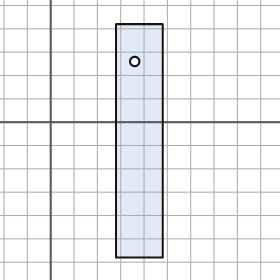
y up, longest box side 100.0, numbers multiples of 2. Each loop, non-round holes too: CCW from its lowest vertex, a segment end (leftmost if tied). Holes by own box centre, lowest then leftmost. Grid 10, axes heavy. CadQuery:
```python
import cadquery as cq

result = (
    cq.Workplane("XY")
    .moveTo(28.0, -58.0)
    .lineTo(48.0, -58.0)
    .lineTo(48.0, 42.0)
    .lineTo(28.0, 42.0)
    .close()
    .moveTo(36.0, 26.0)
    .circle(2.0)
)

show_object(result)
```